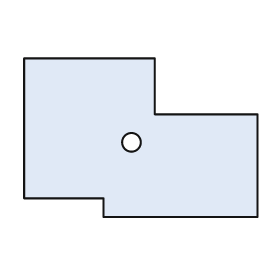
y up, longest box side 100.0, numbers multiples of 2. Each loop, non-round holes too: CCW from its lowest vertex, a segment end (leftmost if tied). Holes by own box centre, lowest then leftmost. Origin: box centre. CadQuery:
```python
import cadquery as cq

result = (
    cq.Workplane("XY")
    .moveTo(-16.0, -34.0)
    .lineTo(50.0, -34.0)
    .lineTo(50.0, 10.0)
    .lineTo(6.0, 10.0)
    .lineTo(6.0, 34.0)
    .lineTo(-50.0, 34.0)
    .lineTo(-50.0, -26.0)
    .lineTo(-16.0, -26.0)
    .close()
    .moveTo(-4.0, -2.0)
    .circle(4.0)
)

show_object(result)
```